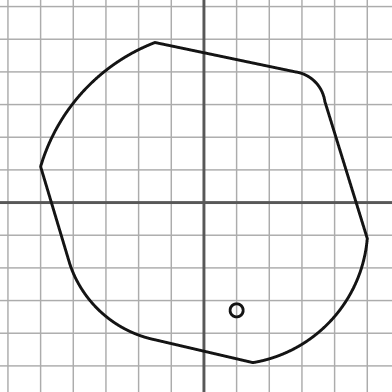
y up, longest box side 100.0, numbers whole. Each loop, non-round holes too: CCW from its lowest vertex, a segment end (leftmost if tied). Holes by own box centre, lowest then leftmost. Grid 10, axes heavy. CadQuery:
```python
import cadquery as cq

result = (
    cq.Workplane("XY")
    .moveTo(15.0, -49.0)
    .threePointArc((39.0, -36.0), (50.0, -11.0))
    .lineTo(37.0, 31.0)
    .threePointArc((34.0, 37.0), (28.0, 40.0))
    .lineTo(-15.0, 49.0)
    .threePointArc((-37.0, 34.0), (-50.0, 11.0))
    .lineTo(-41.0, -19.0)
    .threePointArc((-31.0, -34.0), (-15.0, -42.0))
    .close()
    .moveTo(10.0, -33.0)
    .circle(2.0)
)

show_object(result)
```